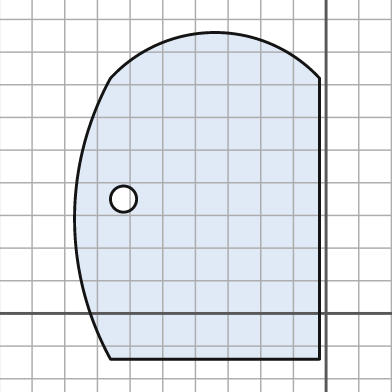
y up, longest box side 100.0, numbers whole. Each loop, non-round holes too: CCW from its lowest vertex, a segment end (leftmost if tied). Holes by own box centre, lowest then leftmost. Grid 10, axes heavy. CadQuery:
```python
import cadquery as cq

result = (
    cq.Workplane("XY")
    .moveTo(-66.0, -14.0)
    .lineTo(-2.0, -14.0)
    .lineTo(-2.0, 72.0)
    .threePointArc((-34.0, 86.0), (-66.0, 72.0))
    .threePointArc((-77.0, 29.0), (-66.0, -14.0))
    .close()
    .moveTo(-62.0, 35.0)
    .circle(4.0)
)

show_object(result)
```